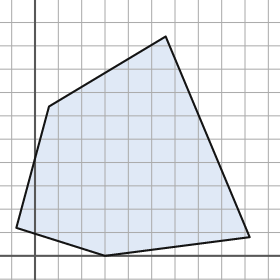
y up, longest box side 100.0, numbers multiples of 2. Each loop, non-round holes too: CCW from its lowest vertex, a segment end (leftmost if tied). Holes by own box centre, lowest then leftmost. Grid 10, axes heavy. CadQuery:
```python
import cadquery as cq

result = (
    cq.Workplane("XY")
    .moveTo(30.0, 0.0)
    .lineTo(92.0, 8.0)
    .lineTo(56.0, 94.0)
    .lineTo(6.0, 64.0)
    .lineTo(-8.0, 12.0)
    .close()
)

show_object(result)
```